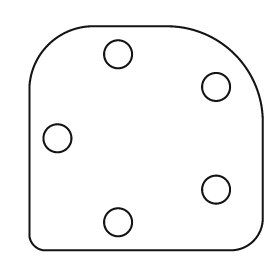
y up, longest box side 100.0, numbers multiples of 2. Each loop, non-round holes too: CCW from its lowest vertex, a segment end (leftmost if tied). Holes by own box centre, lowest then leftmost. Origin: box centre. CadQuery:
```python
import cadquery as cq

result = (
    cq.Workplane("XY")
    .moveTo(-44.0, -48.0)
    .lineTo(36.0, -48.0)
    .threePointArc((46.0, -44.0), (50.0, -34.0))
    .lineTo(50.0, 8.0)
    .threePointArc((38.0, 36.0), (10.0, 48.0))
    .lineTo(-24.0, 48.0)
    .threePointArc((-42.0, 40.0), (-50.0, 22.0))
    .lineTo(-50.0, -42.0)
    .threePointArc((-48.0, -46.0), (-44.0, -48.0))
    .close()
    .moveTo(-12.0, -36.0)
    .circle(6.0)
    .moveTo(30.0, -22.0)
    .circle(6.0)
    .moveTo(-38.0, 0.0)
    .circle(6.0)
    .moveTo(30.0, 22.0)
    .circle(6.0)
    .moveTo(-12.0, 36.0)
    .circle(6.0)
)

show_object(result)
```